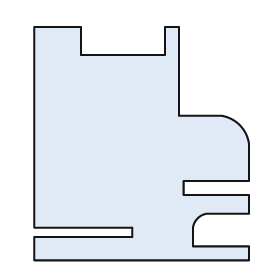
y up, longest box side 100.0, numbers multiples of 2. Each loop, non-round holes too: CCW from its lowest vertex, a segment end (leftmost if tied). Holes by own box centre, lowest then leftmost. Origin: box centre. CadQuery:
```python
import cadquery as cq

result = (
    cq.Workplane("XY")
    .moveTo(-46.0, -50.0)
    .lineTo(46.0, -50.0)
    .lineTo(46.0, -44.0)
    .lineTo(22.0, -44.0)
    .lineTo(22.0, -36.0)
    .threePointArc((24.0, -32.0), (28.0, -30.0))
    .lineTo(46.0, -30.0)
    .lineTo(46.0, -22.0)
    .lineTo(18.0, -22.0)
    .lineTo(18.0, -16.0)
    .lineTo(46.0, -16.0)
    .lineTo(46.0, 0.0)
    .threePointArc((42.0, 8.0), (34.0, 12.0))
    .lineTo(16.0, 12.0)
    .lineTo(16.0, 50.0)
    .lineTo(10.0, 50.0)
    .lineTo(10.0, 38.0)
    .lineTo(-26.0, 38.0)
    .lineTo(-26.0, 50.0)
    .lineTo(-46.0, 50.0)
    .lineTo(-46.0, -36.0)
    .lineTo(-4.0, -36.0)
    .lineTo(-4.0, -40.0)
    .lineTo(-46.0, -40.0)
    .close()
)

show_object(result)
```